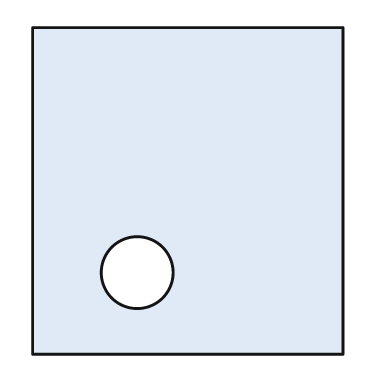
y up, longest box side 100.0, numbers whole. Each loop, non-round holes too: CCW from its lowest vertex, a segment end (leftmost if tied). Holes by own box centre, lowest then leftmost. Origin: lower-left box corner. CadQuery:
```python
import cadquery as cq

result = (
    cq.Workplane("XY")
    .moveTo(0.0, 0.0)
    .lineTo(95.0, 0.0)
    .lineTo(95.0, 100.0)
    .lineTo(0.0, 100.0)
    .close()
    .moveTo(32.0, 25.0)
    .circle(11.0)
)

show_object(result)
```